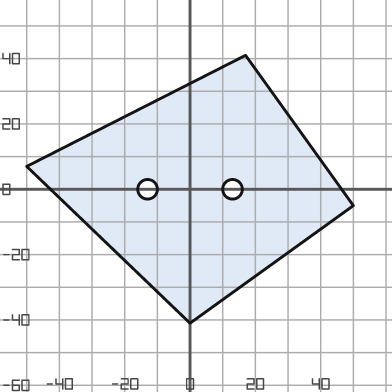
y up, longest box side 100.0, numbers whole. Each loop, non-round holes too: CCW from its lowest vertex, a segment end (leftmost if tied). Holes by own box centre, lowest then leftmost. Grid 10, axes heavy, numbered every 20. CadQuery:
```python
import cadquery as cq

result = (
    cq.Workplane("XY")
    .moveTo(0.0, -41.0)
    .lineTo(50.0, -5.0)
    .lineTo(17.0, 41.0)
    .lineTo(-50.0, 7.0)
    .close()
    .moveTo(-13.0, 0.0)
    .circle(3.0)
    .moveTo(13.0, 0.0)
    .circle(3.0)
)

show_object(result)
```